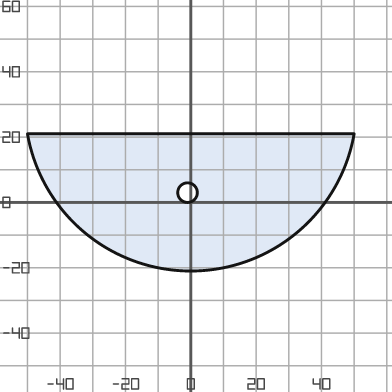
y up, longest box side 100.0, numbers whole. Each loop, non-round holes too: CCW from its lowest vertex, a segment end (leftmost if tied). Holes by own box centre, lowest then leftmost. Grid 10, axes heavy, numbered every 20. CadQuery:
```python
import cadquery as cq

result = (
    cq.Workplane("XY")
    .moveTo(-50.0, 21.0)
    .threePointArc((0.0, -21.0), (50.0, 21.0))
    .close()
    .moveTo(-1.0, 3.0)
    .circle(3.0)
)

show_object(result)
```